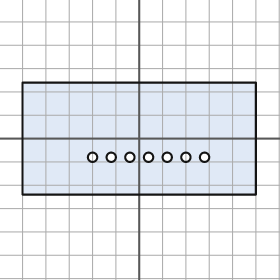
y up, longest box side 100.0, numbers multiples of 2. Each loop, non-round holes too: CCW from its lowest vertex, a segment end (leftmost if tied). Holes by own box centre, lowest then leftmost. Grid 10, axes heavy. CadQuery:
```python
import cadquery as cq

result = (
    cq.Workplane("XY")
    .moveTo(-50.0, -24.0)
    .lineTo(50.0, -24.0)
    .lineTo(50.0, 24.0)
    .lineTo(-50.0, 24.0)
    .close()
    .moveTo(-20.0, -8.0)
    .circle(2.0)
    .moveTo(-12.0, -8.0)
    .circle(2.0)
    .moveTo(-4.0, -8.0)
    .circle(2.0)
    .moveTo(4.0, -8.0)
    .circle(2.0)
    .moveTo(12.0, -8.0)
    .circle(2.0)
    .moveTo(20.0, -8.0)
    .circle(2.0)
    .moveTo(28.0, -8.0)
    .circle(2.0)
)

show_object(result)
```